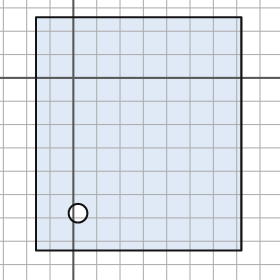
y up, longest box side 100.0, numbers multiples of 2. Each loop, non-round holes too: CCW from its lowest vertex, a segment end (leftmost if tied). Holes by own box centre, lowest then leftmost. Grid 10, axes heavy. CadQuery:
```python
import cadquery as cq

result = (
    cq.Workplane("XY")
    .moveTo(-16.0, -74.0)
    .lineTo(72.0, -74.0)
    .lineTo(72.0, 26.0)
    .lineTo(-16.0, 26.0)
    .close()
    .moveTo(2.0, -58.0)
    .circle(4.0)
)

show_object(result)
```